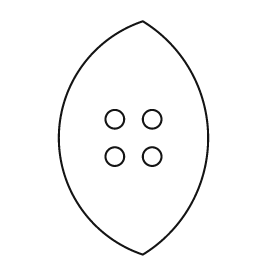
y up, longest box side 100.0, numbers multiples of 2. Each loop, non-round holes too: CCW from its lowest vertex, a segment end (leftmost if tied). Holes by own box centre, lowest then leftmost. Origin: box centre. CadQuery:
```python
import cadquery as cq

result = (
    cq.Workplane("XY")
    .moveTo(4.0, -50.0)
    .threePointArc((32.0, 0.0), (4.0, 50.0))
    .threePointArc((-32.0, 0.0), (4.0, -50.0))
    .close()
    .moveTo(-8.0, -8.0)
    .circle(4.0)
    .moveTo(8.0, -8.0)
    .circle(4.0)
    .moveTo(-8.0, 8.0)
    .circle(4.0)
    .moveTo(8.0, 8.0)
    .circle(4.0)
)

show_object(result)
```